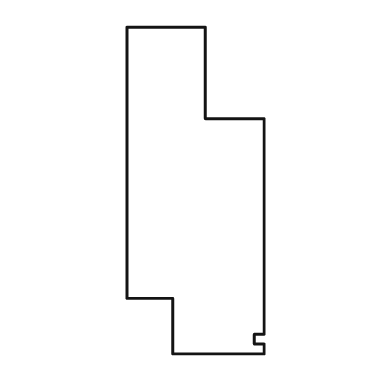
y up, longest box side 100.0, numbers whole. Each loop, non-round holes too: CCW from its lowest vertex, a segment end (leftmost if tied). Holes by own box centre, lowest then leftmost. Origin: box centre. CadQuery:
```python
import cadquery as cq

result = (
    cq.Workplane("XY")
    .moveTo(-7.0, -50.0)
    .lineTo(21.0, -50.0)
    .lineTo(21.0, -47.0)
    .lineTo(18.0, -47.0)
    .lineTo(18.0, -44.0)
    .lineTo(21.0, -44.0)
    .lineTo(21.0, 22.0)
    .lineTo(3.0, 22.0)
    .lineTo(3.0, 50.0)
    .lineTo(-21.0, 50.0)
    .lineTo(-21.0, -33.0)
    .lineTo(-7.0, -33.0)
    .close()
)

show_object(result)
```